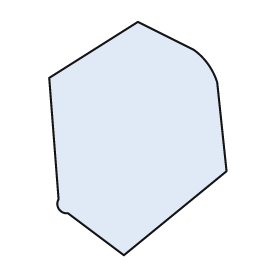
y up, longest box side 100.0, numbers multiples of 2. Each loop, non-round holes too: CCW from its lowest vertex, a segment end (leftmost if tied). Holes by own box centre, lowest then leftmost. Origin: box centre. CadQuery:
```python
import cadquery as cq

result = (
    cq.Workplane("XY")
    .moveTo(-6.0, -50.0)
    .lineTo(38.0, -14.0)
    .lineTo(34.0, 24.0)
    .threePointArc((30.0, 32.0), (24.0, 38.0))
    .lineTo(0.0, 50.0)
    .lineTo(-38.0, 26.0)
    .lineTo(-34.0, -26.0)
    .threePointArc((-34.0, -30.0), (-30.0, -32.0))
    .close()
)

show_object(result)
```